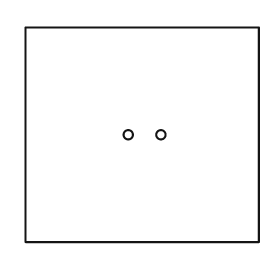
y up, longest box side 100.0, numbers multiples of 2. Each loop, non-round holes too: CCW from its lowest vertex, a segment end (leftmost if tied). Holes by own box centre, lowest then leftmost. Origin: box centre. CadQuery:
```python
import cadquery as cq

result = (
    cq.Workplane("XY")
    .moveTo(-50.0, -46.0)
    .lineTo(50.0, -46.0)
    .lineTo(50.0, 46.0)
    .lineTo(-50.0, 46.0)
    .close()
    .moveTo(-6.0, 0.0)
    .circle(2.0)
    .moveTo(8.0, 0.0)
    .circle(2.0)
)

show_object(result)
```